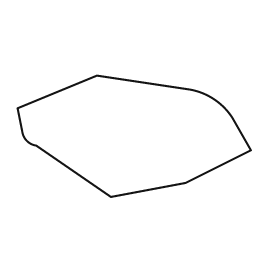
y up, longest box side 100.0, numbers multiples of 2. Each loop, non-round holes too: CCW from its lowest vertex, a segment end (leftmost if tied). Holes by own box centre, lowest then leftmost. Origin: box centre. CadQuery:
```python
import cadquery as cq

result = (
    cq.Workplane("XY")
    .moveTo(-10.0, -26.0)
    .lineTo(22.0, -20.0)
    .lineTo(50.0, -6.0)
    .lineTo(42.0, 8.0)
    .threePointArc((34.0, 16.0), (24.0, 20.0))
    .lineTo(-16.0, 26.0)
    .lineTo(-50.0, 12.0)
    .lineTo(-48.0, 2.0)
    .threePointArc((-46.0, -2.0), (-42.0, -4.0))
    .close()
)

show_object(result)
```